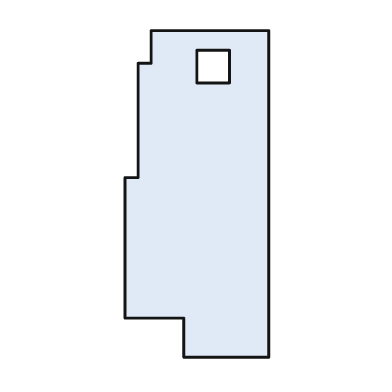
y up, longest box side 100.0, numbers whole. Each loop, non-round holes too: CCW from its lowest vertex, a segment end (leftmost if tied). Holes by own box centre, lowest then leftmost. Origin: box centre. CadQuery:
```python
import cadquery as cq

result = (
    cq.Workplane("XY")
    .moveTo(-4.0, -50.0)
    .lineTo(22.0, -50.0)
    .lineTo(22.0, 50.0)
    .lineTo(-14.0, 50.0)
    .lineTo(-14.0, 40.0)
    .lineTo(-18.0, 40.0)
    .lineTo(-18.0, 5.0)
    .lineTo(-22.0, 5.0)
    .lineTo(-22.0, -38.0)
    .lineTo(-4.0, -38.0)
    .close()
    .moveTo(0.0, 34.0)
    .lineTo(10.0, 34.0)
    .lineTo(10.0, 44.0)
    .lineTo(0.0, 44.0)
    .close()
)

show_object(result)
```